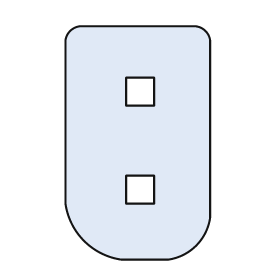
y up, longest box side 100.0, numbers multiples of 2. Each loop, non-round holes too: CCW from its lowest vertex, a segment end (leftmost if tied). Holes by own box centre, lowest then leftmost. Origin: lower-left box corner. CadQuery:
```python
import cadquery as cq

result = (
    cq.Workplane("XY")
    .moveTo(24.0, 0.0)
    .lineTo(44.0, 0.0)
    .threePointArc((56.0, 6.0), (62.0, 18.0))
    .lineTo(62.0, 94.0)
    .threePointArc((60.0, 98.0), (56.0, 100.0))
    .lineTo(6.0, 100.0)
    .threePointArc((2.0, 98.0), (0.0, 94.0))
    .lineTo(0.0, 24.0)
    .threePointArc((8.0, 8.0), (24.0, 0.0))
    .close()
    .moveTo(26.0, 24.0)
    .lineTo(38.0, 24.0)
    .lineTo(38.0, 36.0)
    .lineTo(26.0, 36.0)
    .close()
    .moveTo(26.0, 66.0)
    .lineTo(38.0, 66.0)
    .lineTo(38.0, 78.0)
    .lineTo(26.0, 78.0)
    .close()
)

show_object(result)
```